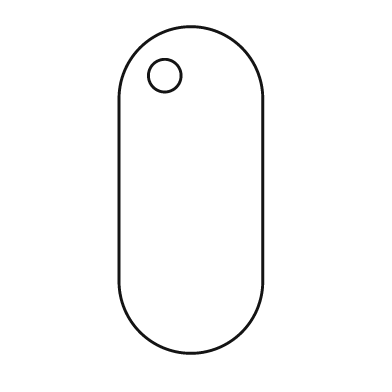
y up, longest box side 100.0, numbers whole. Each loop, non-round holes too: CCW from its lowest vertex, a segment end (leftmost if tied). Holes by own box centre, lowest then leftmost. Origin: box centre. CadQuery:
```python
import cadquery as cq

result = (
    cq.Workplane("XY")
    .moveTo(-22.0, -28.0)
    .threePointArc((0.0, -50.0), (22.0, -28.0))
    .lineTo(22.0, 28.0)
    .threePointArc((0.0, 50.0), (-22.0, 28.0))
    .close()
    .moveTo(-8.0, 35.0)
    .circle(5.0)
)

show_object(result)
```